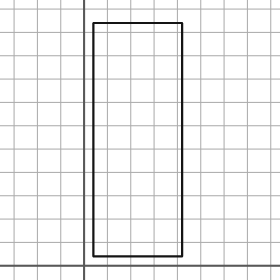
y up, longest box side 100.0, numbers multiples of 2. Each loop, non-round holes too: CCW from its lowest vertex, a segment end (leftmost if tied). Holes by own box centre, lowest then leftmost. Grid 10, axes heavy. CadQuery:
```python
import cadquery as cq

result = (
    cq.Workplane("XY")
    .moveTo(4.0, 4.0)
    .lineTo(42.0, 4.0)
    .lineTo(42.0, 104.0)
    .lineTo(4.0, 104.0)
    .close()
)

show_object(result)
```